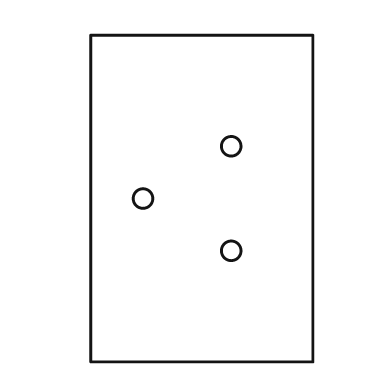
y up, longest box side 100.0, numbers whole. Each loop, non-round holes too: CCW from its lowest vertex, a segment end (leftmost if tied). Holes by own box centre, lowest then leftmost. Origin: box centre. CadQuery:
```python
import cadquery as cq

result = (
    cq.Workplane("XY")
    .moveTo(-34.0, -50.0)
    .lineTo(34.0, -50.0)
    .lineTo(34.0, 50.0)
    .lineTo(-34.0, 50.0)
    .close()
    .moveTo(9.0, -16.0)
    .circle(3.0)
    .moveTo(-18.0, 0.0)
    .circle(3.0)
    .moveTo(9.0, 16.0)
    .circle(3.0)
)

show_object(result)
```